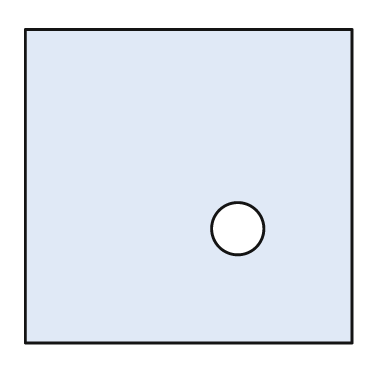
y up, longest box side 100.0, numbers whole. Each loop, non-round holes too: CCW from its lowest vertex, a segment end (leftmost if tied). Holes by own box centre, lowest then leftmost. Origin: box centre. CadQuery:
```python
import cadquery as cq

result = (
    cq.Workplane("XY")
    .moveTo(-50.0, -48.0)
    .lineTo(50.0, -48.0)
    .lineTo(50.0, 48.0)
    .lineTo(-50.0, 48.0)
    .close()
    .moveTo(15.0, -13.0)
    .circle(8.0)
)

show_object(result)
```